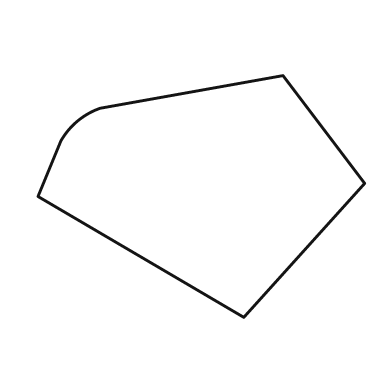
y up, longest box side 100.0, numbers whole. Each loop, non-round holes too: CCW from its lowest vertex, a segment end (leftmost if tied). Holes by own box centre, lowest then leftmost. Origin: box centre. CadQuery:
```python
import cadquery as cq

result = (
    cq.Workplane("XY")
    .moveTo(13.0, -37.0)
    .lineTo(50.0, 4.0)
    .lineTo(25.0, 37.0)
    .lineTo(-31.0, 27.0)
    .threePointArc((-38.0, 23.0), (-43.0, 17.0))
    .lineTo(-50.0, 0.0)
    .close()
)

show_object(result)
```